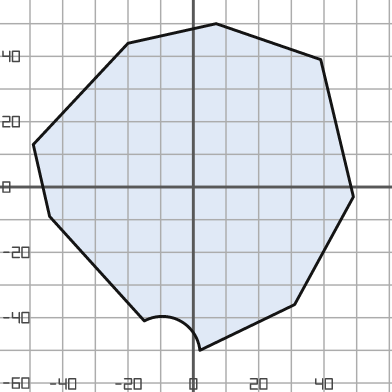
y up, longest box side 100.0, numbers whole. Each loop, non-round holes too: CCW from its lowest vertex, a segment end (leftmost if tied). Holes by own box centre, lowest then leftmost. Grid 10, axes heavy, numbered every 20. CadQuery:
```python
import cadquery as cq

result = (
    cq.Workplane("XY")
    .moveTo(2.0, -50.0)
    .lineTo(31.0, -36.0)
    .lineTo(49.0, -3.0)
    .lineTo(39.0, 39.0)
    .lineTo(7.0, 50.0)
    .lineTo(-20.0, 44.0)
    .lineTo(-49.0, 13.0)
    .lineTo(-44.0, -9.0)
    .lineTo(-15.0, -41.0)
    .threePointArc((-4.0, -41.0), (2.0, -50.0))
    .close()
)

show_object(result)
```